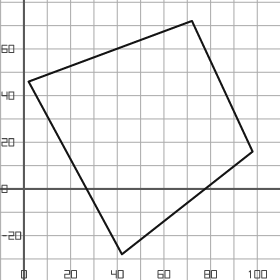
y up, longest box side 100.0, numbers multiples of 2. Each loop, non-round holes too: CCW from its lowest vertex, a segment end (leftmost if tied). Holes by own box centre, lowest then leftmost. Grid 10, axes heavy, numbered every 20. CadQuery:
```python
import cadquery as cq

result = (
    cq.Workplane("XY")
    .moveTo(42.0, -28.0)
    .lineTo(98.0, 16.0)
    .lineTo(72.0, 72.0)
    .lineTo(2.0, 46.0)
    .close()
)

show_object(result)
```